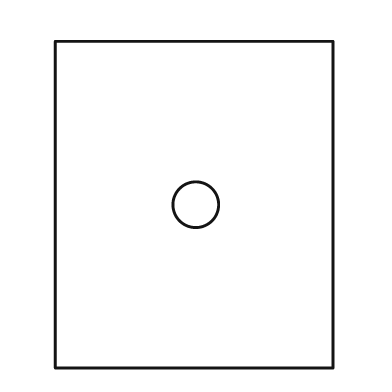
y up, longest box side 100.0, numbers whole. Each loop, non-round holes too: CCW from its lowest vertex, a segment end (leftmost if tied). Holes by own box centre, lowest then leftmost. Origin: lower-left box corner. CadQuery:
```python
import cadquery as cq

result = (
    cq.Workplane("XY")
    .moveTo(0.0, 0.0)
    .lineTo(85.0, 0.0)
    .lineTo(85.0, 100.0)
    .lineTo(0.0, 100.0)
    .close()
    .moveTo(43.0, 50.0)
    .circle(7.0)
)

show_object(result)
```